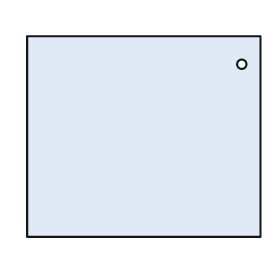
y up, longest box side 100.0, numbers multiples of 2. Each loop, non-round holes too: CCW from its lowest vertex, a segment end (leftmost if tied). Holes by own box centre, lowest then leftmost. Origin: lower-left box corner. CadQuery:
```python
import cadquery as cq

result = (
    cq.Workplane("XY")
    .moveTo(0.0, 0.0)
    .lineTo(100.0, 0.0)
    .lineTo(100.0, 86.0)
    .lineTo(0.0, 86.0)
    .close()
    .moveTo(92.0, 74.0)
    .circle(2.0)
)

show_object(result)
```